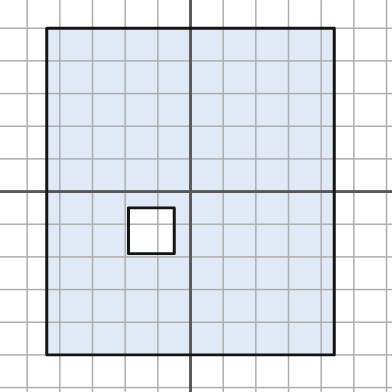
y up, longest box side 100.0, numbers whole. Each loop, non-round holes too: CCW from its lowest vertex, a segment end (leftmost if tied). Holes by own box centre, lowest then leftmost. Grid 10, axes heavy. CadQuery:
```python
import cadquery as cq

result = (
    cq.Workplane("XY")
    .moveTo(-44.0, -50.0)
    .lineTo(44.0, -50.0)
    .lineTo(44.0, 50.0)
    .lineTo(-44.0, 50.0)
    .close()
    .moveTo(-19.0, -19.0)
    .lineTo(-5.0, -19.0)
    .lineTo(-5.0, -5.0)
    .lineTo(-19.0, -5.0)
    .close()
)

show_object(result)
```